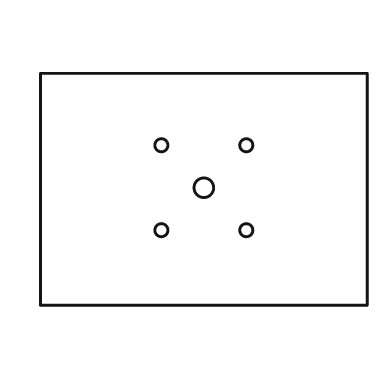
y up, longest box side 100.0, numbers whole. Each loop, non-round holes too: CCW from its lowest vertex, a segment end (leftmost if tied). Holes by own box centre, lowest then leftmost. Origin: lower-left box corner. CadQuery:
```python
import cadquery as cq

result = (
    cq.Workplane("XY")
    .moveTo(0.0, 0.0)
    .lineTo(100.0, 0.0)
    .lineTo(100.0, 71.0)
    .lineTo(0.0, 71.0)
    .close()
    .moveTo(37.0, 23.0)
    .circle(2.0)
    .moveTo(63.0, 23.0)
    .circle(2.0)
    .moveTo(50.0, 36.0)
    .circle(3.0)
    .moveTo(37.0, 49.0)
    .circle(2.0)
    .moveTo(63.0, 49.0)
    .circle(2.0)
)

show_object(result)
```